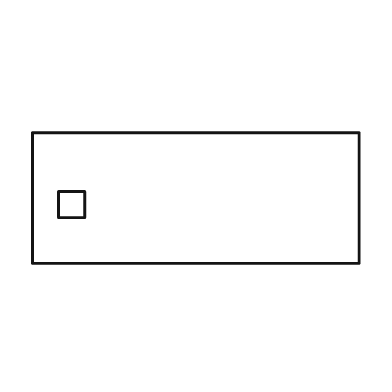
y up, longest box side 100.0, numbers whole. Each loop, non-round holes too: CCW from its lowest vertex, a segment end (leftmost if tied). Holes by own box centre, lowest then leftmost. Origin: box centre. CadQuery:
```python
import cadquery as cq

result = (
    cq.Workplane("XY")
    .moveTo(-50.0, -20.0)
    .lineTo(50.0, -20.0)
    .lineTo(50.0, 20.0)
    .lineTo(-50.0, 20.0)
    .close()
    .moveTo(-42.0, -6.0)
    .lineTo(-34.0, -6.0)
    .lineTo(-34.0, 2.0)
    .lineTo(-42.0, 2.0)
    .close()
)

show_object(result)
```